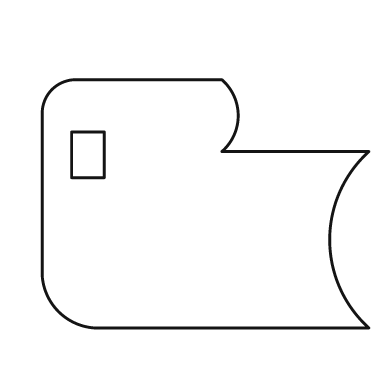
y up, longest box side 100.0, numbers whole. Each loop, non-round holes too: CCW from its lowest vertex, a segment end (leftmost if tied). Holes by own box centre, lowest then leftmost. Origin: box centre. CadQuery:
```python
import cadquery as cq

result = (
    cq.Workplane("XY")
    .moveTo(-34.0, -38.0)
    .lineTo(50.0, -38.0)
    .threePointArc((38.0, -11.0), (50.0, 16.0))
    .lineTo(5.0, 16.0)
    .threePointArc((10.0, 27.0), (5.0, 38.0))
    .lineTo(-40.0, 38.0)
    .threePointArc((-47.0, 35.0), (-50.0, 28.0))
    .lineTo(-50.0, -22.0)
    .threePointArc((-45.0, -33.0), (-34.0, -38.0))
    .close()
    .moveTo(-41.0, 8.0)
    .lineTo(-31.0, 8.0)
    .lineTo(-31.0, 22.0)
    .lineTo(-41.0, 22.0)
    .close()
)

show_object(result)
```